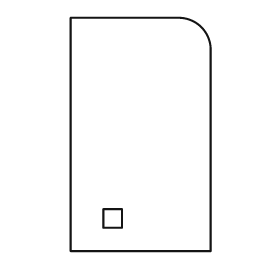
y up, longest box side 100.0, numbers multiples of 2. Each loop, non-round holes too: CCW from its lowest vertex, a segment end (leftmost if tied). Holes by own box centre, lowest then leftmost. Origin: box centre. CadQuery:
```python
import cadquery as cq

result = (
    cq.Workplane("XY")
    .moveTo(-30.0, -50.0)
    .lineTo(30.0, -50.0)
    .lineTo(30.0, 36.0)
    .threePointArc((26.0, 46.0), (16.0, 50.0))
    .lineTo(-30.0, 50.0)
    .close()
    .moveTo(-16.0, -40.0)
    .lineTo(-8.0, -40.0)
    .lineTo(-8.0, -32.0)
    .lineTo(-16.0, -32.0)
    .close()
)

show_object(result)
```